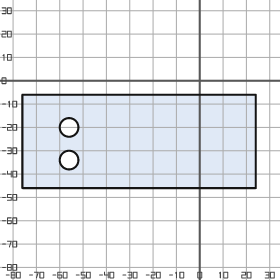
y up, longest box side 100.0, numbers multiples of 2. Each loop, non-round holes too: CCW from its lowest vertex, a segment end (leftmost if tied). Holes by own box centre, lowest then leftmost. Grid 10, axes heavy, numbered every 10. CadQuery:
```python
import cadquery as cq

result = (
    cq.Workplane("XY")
    .moveTo(-76.0, -46.0)
    .lineTo(24.0, -46.0)
    .lineTo(24.0, -6.0)
    .lineTo(-76.0, -6.0)
    .close()
    .moveTo(-56.0, -34.0)
    .circle(4.0)
    .moveTo(-56.0, -20.0)
    .circle(4.0)
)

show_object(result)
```